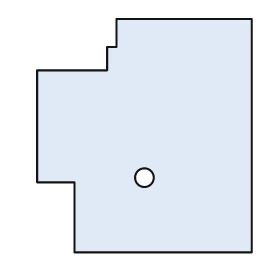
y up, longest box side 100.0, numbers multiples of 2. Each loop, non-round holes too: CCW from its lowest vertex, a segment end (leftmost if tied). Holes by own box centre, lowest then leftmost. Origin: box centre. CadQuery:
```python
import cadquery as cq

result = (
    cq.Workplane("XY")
    .moveTo(-30.0, -50.0)
    .lineTo(46.0, -50.0)
    .lineTo(46.0, 50.0)
    .lineTo(-12.0, 50.0)
    .lineTo(-12.0, 38.0)
    .lineTo(-16.0, 38.0)
    .lineTo(-16.0, 28.0)
    .lineTo(-46.0, 28.0)
    .lineTo(-46.0, -20.0)
    .lineTo(-30.0, -20.0)
    .close()
    .moveTo(0.0, -18.0)
    .circle(4.0)
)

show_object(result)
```